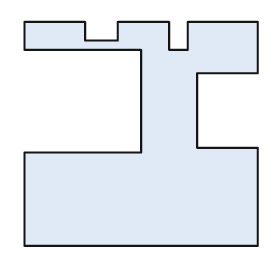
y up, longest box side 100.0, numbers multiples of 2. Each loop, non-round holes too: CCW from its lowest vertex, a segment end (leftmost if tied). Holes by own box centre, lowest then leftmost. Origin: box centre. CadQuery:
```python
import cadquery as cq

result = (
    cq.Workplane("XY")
    .moveTo(-50.0, -48.0)
    .lineTo(50.0, -48.0)
    .lineTo(50.0, -6.0)
    .lineTo(24.0, -6.0)
    .lineTo(24.0, 26.0)
    .lineTo(50.0, 26.0)
    .lineTo(50.0, 48.0)
    .lineTo(20.0, 48.0)
    .lineTo(20.0, 36.0)
    .lineTo(12.0, 36.0)
    .lineTo(12.0, 48.0)
    .lineTo(-10.0, 48.0)
    .lineTo(-10.0, 40.0)
    .lineTo(-24.0, 40.0)
    .lineTo(-24.0, 48.0)
    .lineTo(-50.0, 48.0)
    .lineTo(-50.0, 36.0)
    .lineTo(0.0, 36.0)
    .lineTo(0.0, -8.0)
    .lineTo(-50.0, -8.0)
    .close()
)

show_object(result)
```